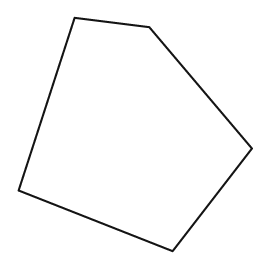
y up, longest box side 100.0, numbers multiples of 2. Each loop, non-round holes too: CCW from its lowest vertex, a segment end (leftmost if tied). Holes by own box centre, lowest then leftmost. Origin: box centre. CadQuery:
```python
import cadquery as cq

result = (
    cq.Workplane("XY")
    .moveTo(16.0, -50.0)
    .lineTo(50.0, -6.0)
    .lineTo(6.0, 46.0)
    .lineTo(-26.0, 50.0)
    .lineTo(-50.0, -24.0)
    .close()
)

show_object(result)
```